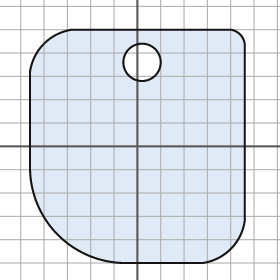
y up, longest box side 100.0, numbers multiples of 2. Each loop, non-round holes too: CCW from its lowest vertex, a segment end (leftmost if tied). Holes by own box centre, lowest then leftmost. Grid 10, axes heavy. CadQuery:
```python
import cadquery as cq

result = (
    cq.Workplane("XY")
    .moveTo(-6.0, -50.0)
    .lineTo(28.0, -50.0)
    .threePointArc((40.0, -44.0), (46.0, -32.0))
    .lineTo(46.0, 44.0)
    .threePointArc((44.0, 48.0), (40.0, 50.0))
    .lineTo(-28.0, 50.0)
    .threePointArc((-40.0, 44.0), (-46.0, 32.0))
    .lineTo(-46.0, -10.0)
    .threePointArc((-34.0, -38.0), (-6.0, -50.0))
    .close()
    .moveTo(2.0, 36.0)
    .circle(8.0)
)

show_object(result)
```